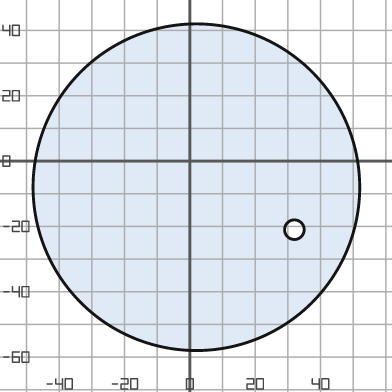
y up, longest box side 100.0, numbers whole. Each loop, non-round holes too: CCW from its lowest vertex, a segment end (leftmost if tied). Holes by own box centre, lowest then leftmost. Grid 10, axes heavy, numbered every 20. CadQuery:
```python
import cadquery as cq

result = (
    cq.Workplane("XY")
    .moveTo(2.0, -8.0)
    .circle(50.0)
    .moveTo(32.0, -21.0)
    .circle(3.0)
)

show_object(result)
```